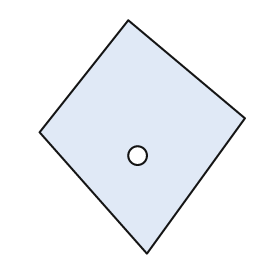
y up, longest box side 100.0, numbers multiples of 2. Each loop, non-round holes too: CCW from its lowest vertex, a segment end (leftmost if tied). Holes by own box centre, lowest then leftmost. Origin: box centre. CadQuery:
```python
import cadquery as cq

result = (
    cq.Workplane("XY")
    .moveTo(2.0, -50.0)
    .lineTo(44.0, 8.0)
    .lineTo(-6.0, 50.0)
    .lineTo(-44.0, 2.0)
    .close()
    .moveTo(-2.0, -8.0)
    .circle(4.0)
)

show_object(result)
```